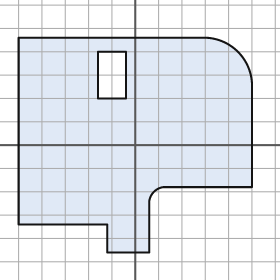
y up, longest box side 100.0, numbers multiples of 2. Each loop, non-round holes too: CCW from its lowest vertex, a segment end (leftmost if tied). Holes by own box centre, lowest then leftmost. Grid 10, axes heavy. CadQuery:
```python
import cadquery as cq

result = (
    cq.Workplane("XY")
    .moveTo(-12.0, -46.0)
    .lineTo(6.0, -46.0)
    .lineTo(6.0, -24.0)
    .threePointArc((8.0, -20.0), (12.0, -18.0))
    .lineTo(50.0, -18.0)
    .lineTo(50.0, 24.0)
    .threePointArc((44.0, 40.0), (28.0, 46.0))
    .lineTo(-50.0, 46.0)
    .lineTo(-50.0, -34.0)
    .lineTo(-12.0, -34.0)
    .close()
    .moveTo(-16.0, 20.0)
    .lineTo(-4.0, 20.0)
    .lineTo(-4.0, 40.0)
    .lineTo(-16.0, 40.0)
    .close()
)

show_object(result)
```